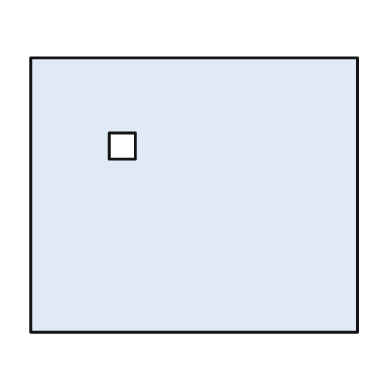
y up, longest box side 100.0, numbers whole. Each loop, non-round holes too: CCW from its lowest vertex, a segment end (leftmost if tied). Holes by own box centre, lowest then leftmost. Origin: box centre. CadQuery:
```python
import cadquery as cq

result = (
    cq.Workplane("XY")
    .moveTo(-50.0, -42.0)
    .lineTo(50.0, -42.0)
    .lineTo(50.0, 42.0)
    .lineTo(-50.0, 42.0)
    .close()
    .moveTo(-26.0, 11.0)
    .lineTo(-18.0, 11.0)
    .lineTo(-18.0, 19.0)
    .lineTo(-26.0, 19.0)
    .close()
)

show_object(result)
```